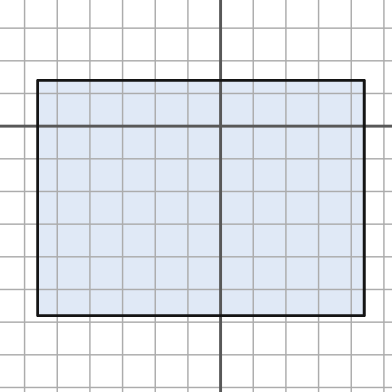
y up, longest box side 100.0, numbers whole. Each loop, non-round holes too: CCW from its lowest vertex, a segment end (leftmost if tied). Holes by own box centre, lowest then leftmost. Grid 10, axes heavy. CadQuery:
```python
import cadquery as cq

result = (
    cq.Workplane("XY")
    .moveTo(-56.0, -58.0)
    .lineTo(44.0, -58.0)
    .lineTo(44.0, 14.0)
    .lineTo(-56.0, 14.0)
    .close()
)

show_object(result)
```